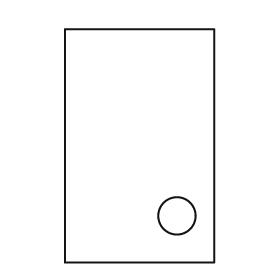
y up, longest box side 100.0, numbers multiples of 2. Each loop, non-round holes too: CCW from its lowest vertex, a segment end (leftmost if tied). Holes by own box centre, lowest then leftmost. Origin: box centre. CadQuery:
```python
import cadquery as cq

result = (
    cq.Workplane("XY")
    .moveTo(-32.0, -50.0)
    .lineTo(32.0, -50.0)
    .lineTo(32.0, 50.0)
    .lineTo(-32.0, 50.0)
    .close()
    .moveTo(16.0, -30.0)
    .circle(8.0)
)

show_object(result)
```